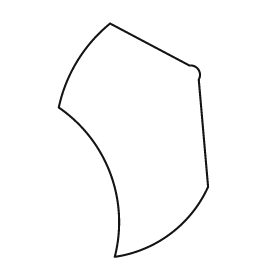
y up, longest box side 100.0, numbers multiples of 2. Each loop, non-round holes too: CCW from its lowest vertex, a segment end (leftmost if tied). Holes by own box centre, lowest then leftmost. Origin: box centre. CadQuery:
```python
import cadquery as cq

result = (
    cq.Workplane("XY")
    .moveTo(-8.0, -50.0)
    .threePointArc((16.0, -40.0), (32.0, -20.0))
    .lineTo(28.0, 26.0)
    .threePointArc((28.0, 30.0), (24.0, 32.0))
    .lineTo(-10.0, 50.0)
    .threePointArc((-24.0, 34.0), (-32.0, 14.0))
    .threePointArc((-10.0, -14.0), (-8.0, -50.0))
    .close()
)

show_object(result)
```